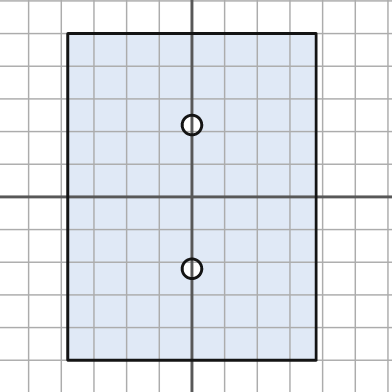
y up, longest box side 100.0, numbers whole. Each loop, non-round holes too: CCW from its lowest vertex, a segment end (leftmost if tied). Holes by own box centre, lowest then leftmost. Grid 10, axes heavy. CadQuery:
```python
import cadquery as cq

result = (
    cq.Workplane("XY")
    .moveTo(-38.0, -50.0)
    .lineTo(38.0, -50.0)
    .lineTo(38.0, 50.0)
    .lineTo(-38.0, 50.0)
    .close()
    .moveTo(0.0, -22.0)
    .circle(3.0)
    .moveTo(0.0, 22.0)
    .circle(3.0)
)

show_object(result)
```